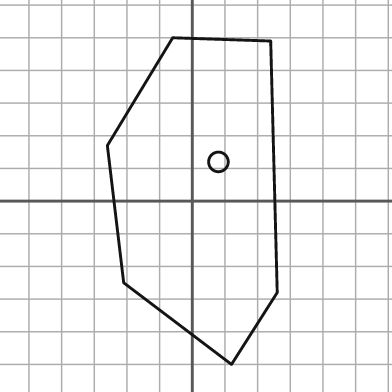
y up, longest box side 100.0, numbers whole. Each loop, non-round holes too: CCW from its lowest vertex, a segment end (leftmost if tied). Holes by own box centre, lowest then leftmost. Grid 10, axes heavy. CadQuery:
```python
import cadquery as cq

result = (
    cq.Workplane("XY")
    .moveTo(12.0, -50.0)
    .lineTo(26.0, -28.0)
    .lineTo(24.0, 49.0)
    .lineTo(-6.0, 50.0)
    .lineTo(-26.0, 17.0)
    .lineTo(-21.0, -25.0)
    .close()
    .moveTo(8.0, 12.0)
    .circle(3.0)
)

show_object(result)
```